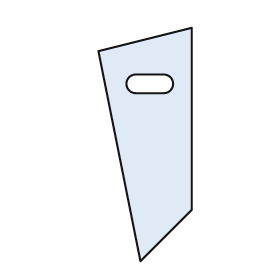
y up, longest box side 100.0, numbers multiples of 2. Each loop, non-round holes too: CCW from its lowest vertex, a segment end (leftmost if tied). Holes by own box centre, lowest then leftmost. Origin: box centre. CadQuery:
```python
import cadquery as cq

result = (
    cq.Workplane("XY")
    .moveTo(-2.0, -50.0)
    .lineTo(20.0, -28.0)
    .lineTo(20.0, 50.0)
    .lineTo(-20.0, 40.0)
    .close()
    .moveTo(-4.0, 22.0)
    .lineTo(8.0, 22.0)
    .threePointArc((12.0, 26.0), (8.0, 30.0))
    .lineTo(-4.0, 30.0)
    .threePointArc((-8.0, 26.0), (-4.0, 22.0))
    .close()
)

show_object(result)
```